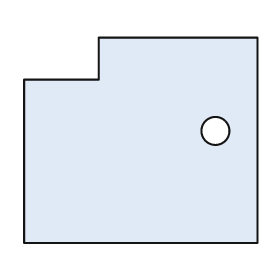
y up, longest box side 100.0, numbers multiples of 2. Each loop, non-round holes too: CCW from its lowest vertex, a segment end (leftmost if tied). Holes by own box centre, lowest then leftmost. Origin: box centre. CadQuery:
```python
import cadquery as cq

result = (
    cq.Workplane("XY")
    .moveTo(-50.0, -44.0)
    .lineTo(50.0, -44.0)
    .lineTo(50.0, 44.0)
    .lineTo(-18.0, 44.0)
    .lineTo(-18.0, 26.0)
    .lineTo(-50.0, 26.0)
    .close()
    .moveTo(32.0, 4.0)
    .circle(6.0)
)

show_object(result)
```